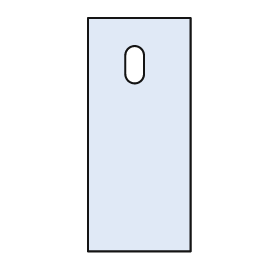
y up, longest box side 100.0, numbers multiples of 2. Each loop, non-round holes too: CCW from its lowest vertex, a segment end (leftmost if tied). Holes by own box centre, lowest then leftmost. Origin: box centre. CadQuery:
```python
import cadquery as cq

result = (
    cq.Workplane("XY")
    .moveTo(-22.0, -50.0)
    .lineTo(22.0, -50.0)
    .lineTo(22.0, 50.0)
    .lineTo(-22.0, 50.0)
    .close()
    .moveTo(-6.0, 26.0)
    .threePointArc((-2.0, 22.0), (2.0, 26.0))
    .lineTo(2.0, 34.0)
    .threePointArc((-2.0, 38.0), (-6.0, 34.0))
    .close()
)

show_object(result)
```